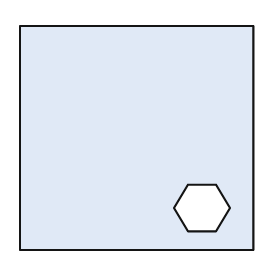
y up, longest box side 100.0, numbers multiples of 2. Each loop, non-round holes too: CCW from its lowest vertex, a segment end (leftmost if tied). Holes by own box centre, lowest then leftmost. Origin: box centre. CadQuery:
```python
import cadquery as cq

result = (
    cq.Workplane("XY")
    .moveTo(-50.0, -48.0)
    .lineTo(50.0, -48.0)
    .lineTo(50.0, 48.0)
    .lineTo(-50.0, 48.0)
    .close()
    .moveTo(22.0, -40.0)
    .lineTo(34.0, -40.0)
    .lineTo(40.0, -30.0)
    .lineTo(34.0, -20.0)
    .lineTo(22.0, -20.0)
    .lineTo(16.0, -30.0)
    .close()
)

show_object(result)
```